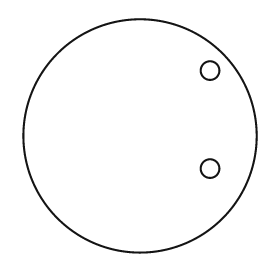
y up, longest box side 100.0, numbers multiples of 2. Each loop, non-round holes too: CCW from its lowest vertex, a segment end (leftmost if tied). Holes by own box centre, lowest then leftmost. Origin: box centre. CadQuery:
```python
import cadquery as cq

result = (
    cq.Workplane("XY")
    .moveTo(0.0, 0.0)
    .circle(50.0)
    .moveTo(30.0, -14.0)
    .circle(4.0)
    .moveTo(30.0, 28.0)
    .circle(4.0)
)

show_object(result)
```